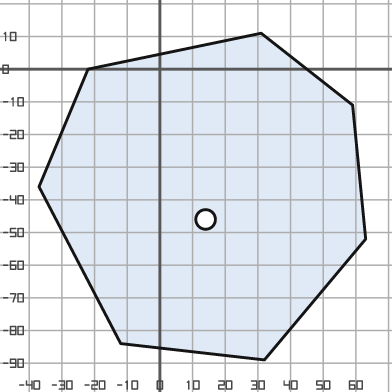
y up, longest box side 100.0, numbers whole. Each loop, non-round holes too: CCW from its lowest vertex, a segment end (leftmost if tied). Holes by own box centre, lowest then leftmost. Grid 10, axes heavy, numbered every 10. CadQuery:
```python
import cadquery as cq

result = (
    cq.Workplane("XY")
    .moveTo(32.0, -89.0)
    .lineTo(63.0, -52.0)
    .lineTo(59.0, -11.0)
    .lineTo(31.0, 11.0)
    .lineTo(-22.0, 0.0)
    .lineTo(-37.0, -36.0)
    .lineTo(-12.0, -84.0)
    .close()
    .moveTo(14.0, -46.0)
    .circle(3.0)
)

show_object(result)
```